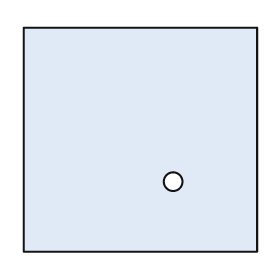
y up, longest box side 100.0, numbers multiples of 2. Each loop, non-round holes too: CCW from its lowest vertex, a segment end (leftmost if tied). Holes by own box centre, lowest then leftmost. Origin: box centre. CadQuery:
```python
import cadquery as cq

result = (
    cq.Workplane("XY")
    .moveTo(-50.0, -48.0)
    .lineTo(50.0, -48.0)
    .lineTo(50.0, 48.0)
    .lineTo(-50.0, 48.0)
    .close()
    .moveTo(14.0, -18.0)
    .circle(4.0)
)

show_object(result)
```